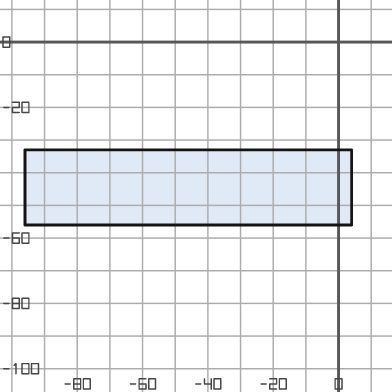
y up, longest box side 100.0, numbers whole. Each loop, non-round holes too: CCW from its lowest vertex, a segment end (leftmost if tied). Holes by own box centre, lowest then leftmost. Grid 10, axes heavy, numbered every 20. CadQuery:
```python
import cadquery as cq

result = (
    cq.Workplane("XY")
    .moveTo(-96.0, -56.0)
    .lineTo(4.0, -56.0)
    .lineTo(4.0, -33.0)
    .lineTo(-96.0, -33.0)
    .close()
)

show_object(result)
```